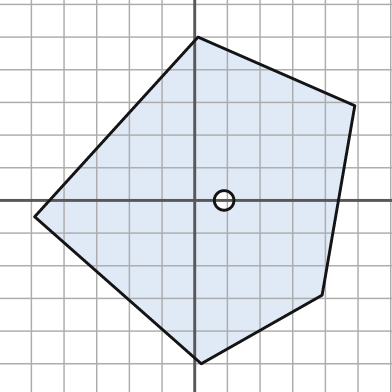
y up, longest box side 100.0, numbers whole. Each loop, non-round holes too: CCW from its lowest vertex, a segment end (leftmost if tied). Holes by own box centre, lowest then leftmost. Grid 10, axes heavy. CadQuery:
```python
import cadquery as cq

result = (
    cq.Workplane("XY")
    .moveTo(2.0, -50.0)
    .lineTo(39.0, -29.0)
    .lineTo(49.0, 29.0)
    .lineTo(1.0, 50.0)
    .lineTo(-49.0, -5.0)
    .close()
    .moveTo(9.0, 0.0)
    .circle(3.0)
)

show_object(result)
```